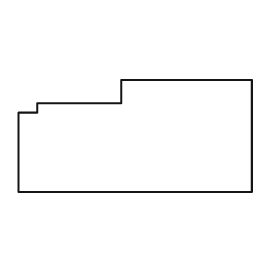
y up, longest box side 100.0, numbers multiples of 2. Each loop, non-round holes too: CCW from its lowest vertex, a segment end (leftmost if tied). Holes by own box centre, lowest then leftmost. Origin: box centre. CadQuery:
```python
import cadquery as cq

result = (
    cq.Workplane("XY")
    .moveTo(-50.0, -24.0)
    .lineTo(50.0, -24.0)
    .lineTo(50.0, 24.0)
    .lineTo(-6.0, 24.0)
    .lineTo(-6.0, 14.0)
    .lineTo(-42.0, 14.0)
    .lineTo(-42.0, 10.0)
    .lineTo(-50.0, 10.0)
    .close()
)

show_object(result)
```